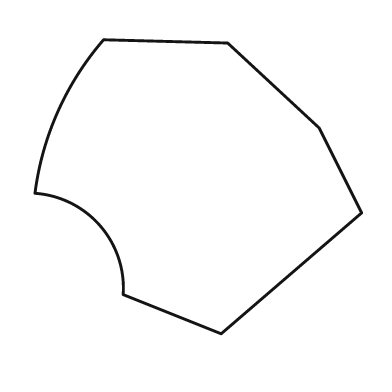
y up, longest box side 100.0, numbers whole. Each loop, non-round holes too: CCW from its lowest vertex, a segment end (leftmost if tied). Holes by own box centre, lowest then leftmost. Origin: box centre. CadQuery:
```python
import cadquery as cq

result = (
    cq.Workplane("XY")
    .moveTo(7.0, -45.0)
    .lineTo(50.0, -8.0)
    .lineTo(37.0, 18.0)
    .lineTo(9.0, 44.0)
    .lineTo(-29.0, 45.0)
    .threePointArc((-43.0, 23.0), (-50.0, -2.0))
    .threePointArc((-30.0, -12.0), (-23.0, -33.0))
    .close()
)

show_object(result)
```